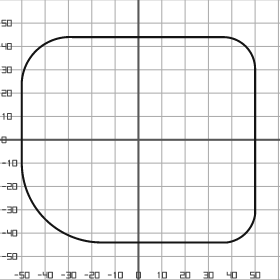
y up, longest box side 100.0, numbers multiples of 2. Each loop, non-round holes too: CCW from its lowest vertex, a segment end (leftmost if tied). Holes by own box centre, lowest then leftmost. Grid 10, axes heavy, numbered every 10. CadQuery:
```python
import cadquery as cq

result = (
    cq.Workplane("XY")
    .moveTo(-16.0, -44.0)
    .lineTo(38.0, -44.0)
    .threePointArc((46.0, -40.0), (50.0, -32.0))
    .lineTo(50.0, 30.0)
    .threePointArc((46.0, 40.0), (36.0, 44.0))
    .lineTo(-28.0, 44.0)
    .threePointArc((-44.0, 38.0), (-50.0, 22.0))
    .lineTo(-50.0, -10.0)
    .threePointArc((-40.0, -34.0), (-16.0, -44.0))
    .close()
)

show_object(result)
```